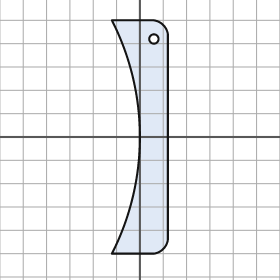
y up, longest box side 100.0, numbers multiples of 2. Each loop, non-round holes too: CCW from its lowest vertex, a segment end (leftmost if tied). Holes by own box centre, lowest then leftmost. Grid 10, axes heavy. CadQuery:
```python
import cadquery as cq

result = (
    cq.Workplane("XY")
    .moveTo(-12.0, -50.0)
    .lineTo(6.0, -50.0)
    .threePointArc((10.0, -48.0), (12.0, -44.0))
    .lineTo(12.0, 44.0)
    .threePointArc((10.0, 48.0), (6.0, 50.0))
    .lineTo(-12.0, 50.0)
    .threePointArc((0.0, 0.0), (-12.0, -50.0))
    .close()
    .moveTo(6.0, 42.0)
    .circle(2.0)
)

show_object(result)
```